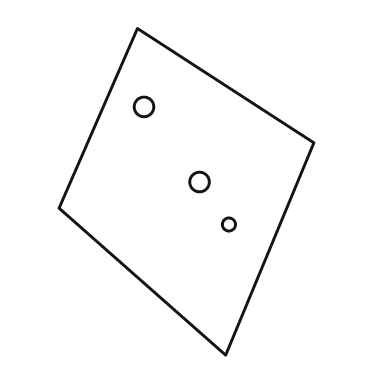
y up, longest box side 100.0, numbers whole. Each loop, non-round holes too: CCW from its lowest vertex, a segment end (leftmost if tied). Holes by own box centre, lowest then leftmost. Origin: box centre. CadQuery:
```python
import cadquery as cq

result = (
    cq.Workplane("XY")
    .moveTo(12.0, -50.0)
    .lineTo(39.0, 15.0)
    .lineTo(-15.0, 50.0)
    .lineTo(-39.0, -5.0)
    .close()
    .moveTo(13.0, -10.0)
    .circle(2.0)
    .moveTo(4.0, 3.0)
    .circle(3.0)
    .moveTo(-13.0, 26.0)
    .circle(3.0)
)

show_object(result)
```